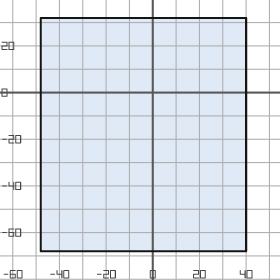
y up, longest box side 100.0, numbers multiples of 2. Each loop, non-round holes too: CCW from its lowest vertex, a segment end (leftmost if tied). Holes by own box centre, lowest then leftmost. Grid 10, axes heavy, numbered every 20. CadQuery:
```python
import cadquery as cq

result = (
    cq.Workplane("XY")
    .moveTo(-48.0, -68.0)
    .lineTo(40.0, -68.0)
    .lineTo(40.0, 32.0)
    .lineTo(-48.0, 32.0)
    .close()
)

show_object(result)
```